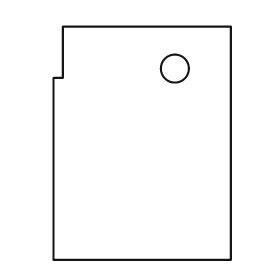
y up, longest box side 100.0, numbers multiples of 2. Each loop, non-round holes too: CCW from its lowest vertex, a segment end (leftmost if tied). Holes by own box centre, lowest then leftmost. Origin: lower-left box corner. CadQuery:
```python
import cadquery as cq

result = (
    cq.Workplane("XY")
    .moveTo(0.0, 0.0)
    .lineTo(76.0, 0.0)
    .lineTo(76.0, 100.0)
    .lineTo(4.0, 100.0)
    .lineTo(4.0, 78.0)
    .lineTo(0.0, 78.0)
    .close()
    .moveTo(52.0, 82.0)
    .circle(6.0)
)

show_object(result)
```